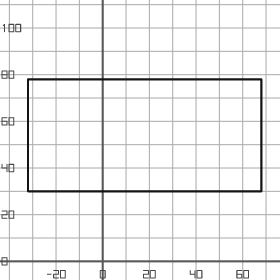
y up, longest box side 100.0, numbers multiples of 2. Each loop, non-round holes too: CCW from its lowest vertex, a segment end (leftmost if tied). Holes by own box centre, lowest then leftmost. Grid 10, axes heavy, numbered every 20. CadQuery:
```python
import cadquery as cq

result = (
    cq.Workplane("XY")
    .moveTo(-32.0, 30.0)
    .lineTo(68.0, 30.0)
    .lineTo(68.0, 78.0)
    .lineTo(-32.0, 78.0)
    .close()
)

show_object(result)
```